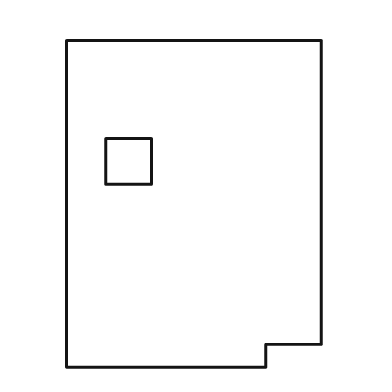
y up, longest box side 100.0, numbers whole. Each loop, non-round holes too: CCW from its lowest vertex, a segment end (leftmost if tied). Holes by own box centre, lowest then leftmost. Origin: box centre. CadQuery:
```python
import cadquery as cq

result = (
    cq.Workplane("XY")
    .moveTo(-39.0, -50.0)
    .lineTo(22.0, -50.0)
    .lineTo(22.0, -43.0)
    .lineTo(39.0, -43.0)
    .lineTo(39.0, 50.0)
    .lineTo(-39.0, 50.0)
    .close()
    .moveTo(-27.0, 6.0)
    .lineTo(-13.0, 6.0)
    .lineTo(-13.0, 20.0)
    .lineTo(-27.0, 20.0)
    .close()
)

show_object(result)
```